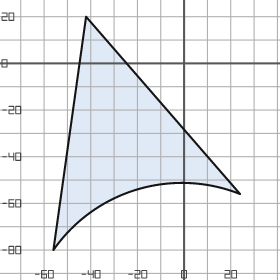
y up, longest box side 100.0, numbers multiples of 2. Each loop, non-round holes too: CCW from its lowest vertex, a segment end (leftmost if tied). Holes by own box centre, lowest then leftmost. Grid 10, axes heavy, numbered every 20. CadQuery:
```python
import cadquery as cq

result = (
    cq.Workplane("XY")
    .moveTo(-56.0, -80.0)
    .threePointArc((-20.0, -54.0), (24.0, -56.0))
    .lineTo(-42.0, 20.0)
    .close()
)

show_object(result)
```